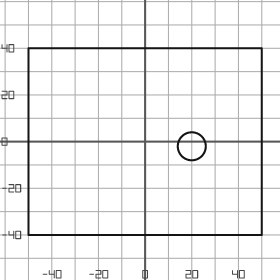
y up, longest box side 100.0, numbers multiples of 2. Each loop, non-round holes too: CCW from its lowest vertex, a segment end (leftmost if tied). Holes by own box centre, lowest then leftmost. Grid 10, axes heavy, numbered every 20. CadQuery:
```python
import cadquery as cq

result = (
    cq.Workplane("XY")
    .moveTo(-50.0, -40.0)
    .lineTo(50.0, -40.0)
    .lineTo(50.0, 40.0)
    .lineTo(-50.0, 40.0)
    .close()
    .moveTo(20.0, -2.0)
    .circle(6.0)
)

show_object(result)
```